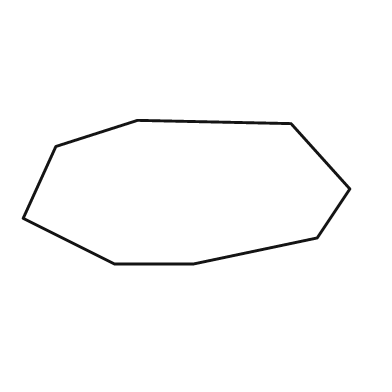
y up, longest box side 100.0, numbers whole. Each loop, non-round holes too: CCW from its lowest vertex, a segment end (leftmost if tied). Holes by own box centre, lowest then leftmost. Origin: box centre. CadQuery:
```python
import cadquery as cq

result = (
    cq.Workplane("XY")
    .moveTo(-22.0, -22.0)
    .lineTo(2.0, -22.0)
    .lineTo(40.0, -14.0)
    .lineTo(50.0, 1.0)
    .lineTo(32.0, 21.0)
    .lineTo(-15.0, 22.0)
    .lineTo(-40.0, 14.0)
    .lineTo(-50.0, -8.0)
    .close()
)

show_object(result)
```